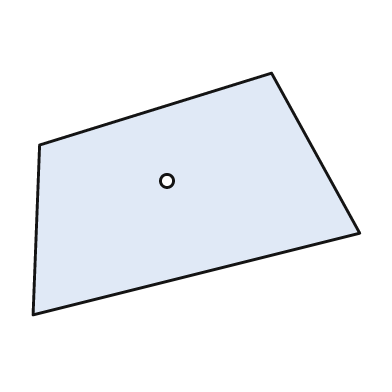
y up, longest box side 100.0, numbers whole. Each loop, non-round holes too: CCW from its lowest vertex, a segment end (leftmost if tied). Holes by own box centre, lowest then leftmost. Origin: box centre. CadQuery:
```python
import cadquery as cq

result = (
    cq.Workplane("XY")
    .moveTo(-50.0, -37.0)
    .lineTo(50.0, -12.0)
    .lineTo(23.0, 37.0)
    .lineTo(-48.0, 15.0)
    .close()
    .moveTo(-9.0, 4.0)
    .circle(2.0)
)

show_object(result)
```